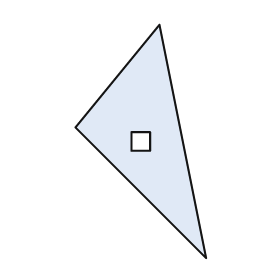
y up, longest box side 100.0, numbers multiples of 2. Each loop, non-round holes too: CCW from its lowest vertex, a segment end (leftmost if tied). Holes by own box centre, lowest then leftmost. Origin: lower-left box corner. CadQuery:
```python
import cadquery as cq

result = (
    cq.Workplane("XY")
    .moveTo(56.0, 0.0)
    .lineTo(36.0, 100.0)
    .lineTo(0.0, 56.0)
    .close()
    .moveTo(24.0, 46.0)
    .lineTo(32.0, 46.0)
    .lineTo(32.0, 54.0)
    .lineTo(24.0, 54.0)
    .close()
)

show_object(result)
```